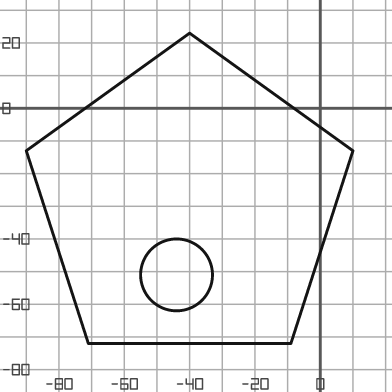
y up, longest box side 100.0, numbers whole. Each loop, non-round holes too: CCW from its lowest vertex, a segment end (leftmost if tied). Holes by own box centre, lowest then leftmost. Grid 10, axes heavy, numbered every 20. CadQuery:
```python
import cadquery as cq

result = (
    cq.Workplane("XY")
    .moveTo(-71.0, -72.0)
    .lineTo(-9.0, -72.0)
    .lineTo(10.0, -13.0)
    .lineTo(-40.0, 23.0)
    .lineTo(-90.0, -13.0)
    .close()
    .moveTo(-44.0, -51.0)
    .circle(11.0)
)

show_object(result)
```